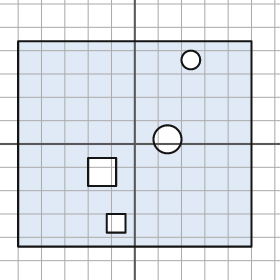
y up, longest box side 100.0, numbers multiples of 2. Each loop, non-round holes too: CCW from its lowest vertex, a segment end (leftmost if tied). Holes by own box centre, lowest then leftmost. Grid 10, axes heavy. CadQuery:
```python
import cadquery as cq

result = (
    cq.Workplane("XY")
    .moveTo(-50.0, -44.0)
    .lineTo(50.0, -44.0)
    .lineTo(50.0, 44.0)
    .lineTo(-50.0, 44.0)
    .close()
    .moveTo(-12.0, -38.0)
    .lineTo(-4.0, -38.0)
    .lineTo(-4.0, -30.0)
    .lineTo(-12.0, -30.0)
    .close()
    .moveTo(-20.0, -18.0)
    .lineTo(-8.0, -18.0)
    .lineTo(-8.0, -6.0)
    .lineTo(-20.0, -6.0)
    .close()
    .moveTo(14.0, 2.0)
    .circle(6.0)
    .moveTo(24.0, 36.0)
    .circle(4.0)
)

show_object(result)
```